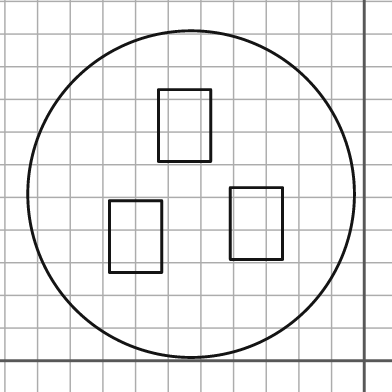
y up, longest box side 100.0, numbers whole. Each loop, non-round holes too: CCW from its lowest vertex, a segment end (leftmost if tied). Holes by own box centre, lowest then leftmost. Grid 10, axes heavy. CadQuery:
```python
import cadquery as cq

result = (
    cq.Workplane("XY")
    .moveTo(-53.0, 51.0)
    .circle(50.0)
    .moveTo(-78.0, 27.0)
    .lineTo(-62.0, 27.0)
    .lineTo(-62.0, 49.0)
    .lineTo(-78.0, 49.0)
    .close()
    .moveTo(-41.0, 31.0)
    .lineTo(-25.0, 31.0)
    .lineTo(-25.0, 53.0)
    .lineTo(-41.0, 53.0)
    .close()
    .moveTo(-63.0, 61.0)
    .lineTo(-47.0, 61.0)
    .lineTo(-47.0, 83.0)
    .lineTo(-63.0, 83.0)
    .close()
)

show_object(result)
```